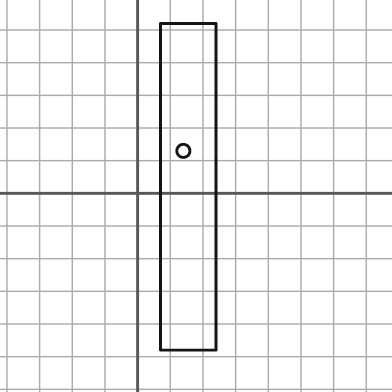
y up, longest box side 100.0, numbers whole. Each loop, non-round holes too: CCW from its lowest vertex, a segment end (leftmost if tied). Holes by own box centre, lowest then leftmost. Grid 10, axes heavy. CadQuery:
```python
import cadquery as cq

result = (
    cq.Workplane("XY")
    .moveTo(7.0, -48.0)
    .lineTo(24.0, -48.0)
    .lineTo(24.0, 52.0)
    .lineTo(7.0, 52.0)
    .close()
    .moveTo(14.0, 13.0)
    .circle(2.0)
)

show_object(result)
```